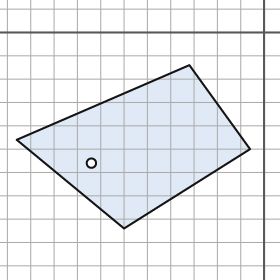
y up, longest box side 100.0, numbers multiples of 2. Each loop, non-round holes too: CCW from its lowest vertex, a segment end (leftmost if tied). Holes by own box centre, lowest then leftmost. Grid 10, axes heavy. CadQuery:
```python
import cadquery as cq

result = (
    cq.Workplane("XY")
    .moveTo(-60.0, -84.0)
    .lineTo(-6.0, -50.0)
    .lineTo(-32.0, -14.0)
    .lineTo(-106.0, -46.0)
    .close()
    .moveTo(-74.0, -56.0)
    .circle(2.0)
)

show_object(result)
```